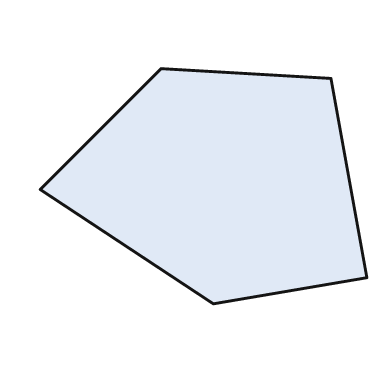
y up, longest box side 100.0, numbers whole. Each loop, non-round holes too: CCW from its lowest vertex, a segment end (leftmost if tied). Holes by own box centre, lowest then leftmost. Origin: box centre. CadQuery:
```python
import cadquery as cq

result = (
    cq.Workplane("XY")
    .moveTo(3.0, -36.0)
    .lineTo(50.0, -28.0)
    .lineTo(39.0, 33.0)
    .lineTo(-13.0, 36.0)
    .lineTo(-50.0, -1.0)
    .close()
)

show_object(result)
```